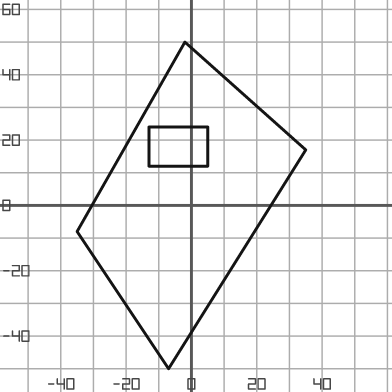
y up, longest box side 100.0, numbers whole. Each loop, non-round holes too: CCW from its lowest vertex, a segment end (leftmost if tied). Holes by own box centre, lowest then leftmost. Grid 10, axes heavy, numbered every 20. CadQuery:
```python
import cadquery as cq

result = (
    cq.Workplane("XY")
    .moveTo(-7.0, -50.0)
    .lineTo(35.0, 17.0)
    .lineTo(-2.0, 50.0)
    .lineTo(-35.0, -8.0)
    .close()
    .moveTo(-13.0, 12.0)
    .lineTo(5.0, 12.0)
    .lineTo(5.0, 24.0)
    .lineTo(-13.0, 24.0)
    .close()
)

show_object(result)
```